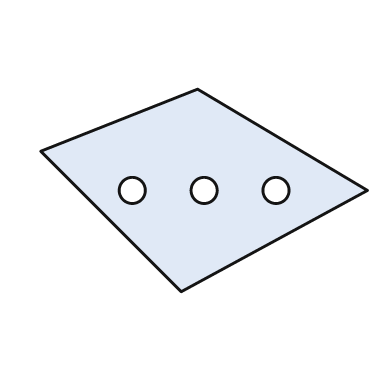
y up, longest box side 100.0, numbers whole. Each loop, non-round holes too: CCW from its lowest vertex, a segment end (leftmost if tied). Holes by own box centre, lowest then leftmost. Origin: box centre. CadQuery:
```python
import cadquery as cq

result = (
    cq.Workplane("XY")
    .moveTo(-7.0, -31.0)
    .lineTo(50.0, 0.0)
    .lineTo(-2.0, 31.0)
    .lineTo(-50.0, 12.0)
    .close()
    .moveTo(-22.0, 0.0)
    .circle(4.0)
    .moveTo(0.0, 0.0)
    .circle(4.0)
    .moveTo(22.0, 0.0)
    .circle(4.0)
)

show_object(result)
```